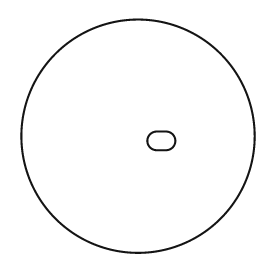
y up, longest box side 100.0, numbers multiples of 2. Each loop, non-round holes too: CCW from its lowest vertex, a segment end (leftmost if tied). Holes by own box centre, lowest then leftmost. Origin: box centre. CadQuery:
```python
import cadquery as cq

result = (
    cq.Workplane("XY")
    .moveTo(0.0, 0.0)
    .circle(50.0)
    .moveTo(8.0, -6.0)
    .lineTo(12.0, -6.0)
    .threePointArc((16.0, -2.0), (12.0, 2.0))
    .lineTo(8.0, 2.0)
    .threePointArc((4.0, -2.0), (8.0, -6.0))
    .close()
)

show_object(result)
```